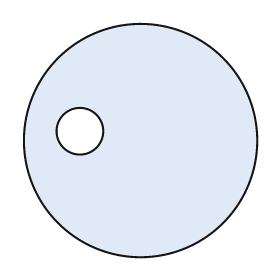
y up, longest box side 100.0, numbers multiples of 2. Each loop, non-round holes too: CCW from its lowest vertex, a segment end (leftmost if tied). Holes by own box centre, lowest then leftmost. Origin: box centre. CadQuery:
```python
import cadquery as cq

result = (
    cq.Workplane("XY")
    .moveTo(0.0, 0.0)
    .circle(50.0)
    .moveTo(-26.0, 4.0)
    .circle(10.0)
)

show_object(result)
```